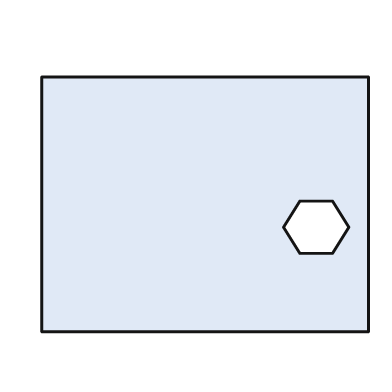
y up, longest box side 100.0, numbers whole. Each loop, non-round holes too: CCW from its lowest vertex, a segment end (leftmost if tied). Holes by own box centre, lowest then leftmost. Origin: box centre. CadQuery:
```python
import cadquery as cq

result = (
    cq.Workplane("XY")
    .moveTo(-50.0, -39.0)
    .lineTo(50.0, -39.0)
    .lineTo(50.0, 39.0)
    .lineTo(-50.0, 39.0)
    .close()
    .moveTo(29.0, -15.0)
    .lineTo(39.0, -15.0)
    .lineTo(44.0, -7.0)
    .lineTo(39.0, 1.0)
    .lineTo(29.0, 1.0)
    .lineTo(24.0, -7.0)
    .close()
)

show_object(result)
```